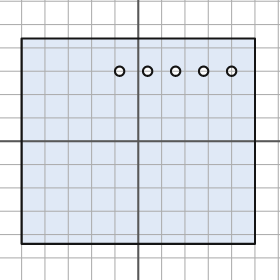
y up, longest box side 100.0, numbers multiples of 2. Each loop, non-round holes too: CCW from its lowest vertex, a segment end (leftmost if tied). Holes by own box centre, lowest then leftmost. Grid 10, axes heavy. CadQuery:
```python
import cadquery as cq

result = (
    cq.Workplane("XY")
    .moveTo(-50.0, -44.0)
    .lineTo(50.0, -44.0)
    .lineTo(50.0, 44.0)
    .lineTo(-50.0, 44.0)
    .close()
    .moveTo(-8.0, 30.0)
    .circle(2.0)
    .moveTo(4.0, 30.0)
    .circle(2.0)
    .moveTo(16.0, 30.0)
    .circle(2.0)
    .moveTo(28.0, 30.0)
    .circle(2.0)
    .moveTo(40.0, 30.0)
    .circle(2.0)
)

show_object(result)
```